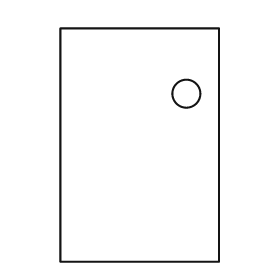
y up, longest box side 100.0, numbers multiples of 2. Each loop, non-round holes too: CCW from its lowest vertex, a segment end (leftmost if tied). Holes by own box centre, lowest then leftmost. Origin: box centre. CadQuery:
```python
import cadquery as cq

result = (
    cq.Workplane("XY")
    .moveTo(-34.0, -50.0)
    .lineTo(34.0, -50.0)
    .lineTo(34.0, 50.0)
    .lineTo(-34.0, 50.0)
    .close()
    .moveTo(20.0, 22.0)
    .circle(6.0)
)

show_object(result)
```